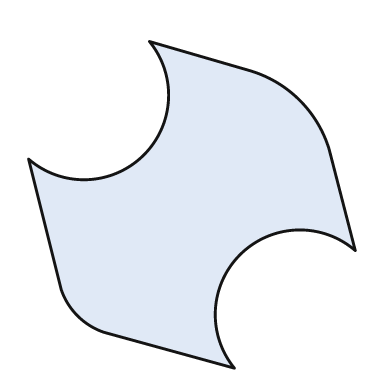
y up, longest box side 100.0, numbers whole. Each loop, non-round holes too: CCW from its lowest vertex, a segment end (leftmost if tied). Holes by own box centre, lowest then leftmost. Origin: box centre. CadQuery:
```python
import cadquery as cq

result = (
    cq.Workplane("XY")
    .moveTo(13.0, -50.0)
    .threePointArc((15.0, -15.0), (50.0, -14.0))
    .lineTo(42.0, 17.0)
    .threePointArc((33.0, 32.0), (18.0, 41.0))
    .lineTo(-13.0, 50.0)
    .threePointArc((-15.0, 15.0), (-50.0, 14.0))
    .lineTo(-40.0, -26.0)
    .threePointArc((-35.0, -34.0), (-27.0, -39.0))
    .close()
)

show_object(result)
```